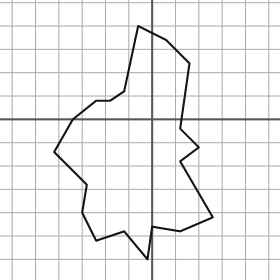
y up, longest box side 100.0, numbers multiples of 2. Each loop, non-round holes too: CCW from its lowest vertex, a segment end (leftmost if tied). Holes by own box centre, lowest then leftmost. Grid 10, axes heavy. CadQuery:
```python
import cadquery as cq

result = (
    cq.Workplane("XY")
    .moveTo(-2.0, -60.0)
    .lineTo(0.0, -46.0)
    .lineTo(12.0, -48.0)
    .lineTo(26.0, -42.0)
    .lineTo(12.0, -18.0)
    .lineTo(20.0, -12.0)
    .lineTo(12.0, -4.0)
    .lineTo(16.0, 24.0)
    .lineTo(6.0, 34.0)
    .lineTo(-6.0, 40.0)
    .lineTo(-12.0, 12.0)
    .lineTo(-18.0, 8.0)
    .lineTo(-24.0, 8.0)
    .lineTo(-34.0, 0.0)
    .lineTo(-42.0, -14.0)
    .lineTo(-28.0, -28.0)
    .lineTo(-30.0, -40.0)
    .lineTo(-24.0, -52.0)
    .lineTo(-12.0, -48.0)
    .close()
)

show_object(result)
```